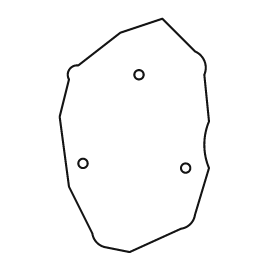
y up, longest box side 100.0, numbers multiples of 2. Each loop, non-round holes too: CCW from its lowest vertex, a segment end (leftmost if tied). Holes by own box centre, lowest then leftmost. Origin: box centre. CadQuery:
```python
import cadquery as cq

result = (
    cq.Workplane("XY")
    .moveTo(-2.0, -50.0)
    .lineTo(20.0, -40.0)
    .threePointArc((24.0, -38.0), (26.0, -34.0))
    .lineTo(32.0, -14.0)
    .threePointArc((30.0, -4.0), (32.0, 6.0))
    .lineTo(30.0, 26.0)
    .threePointArc((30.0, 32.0), (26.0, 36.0))
    .lineTo(12.0, 50.0)
    .lineTo(-6.0, 44.0)
    .lineTo(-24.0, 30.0)
    .threePointArc((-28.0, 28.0), (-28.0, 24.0))
    .lineTo(-32.0, 8.0)
    .lineTo(-28.0, -22.0)
    .lineTo(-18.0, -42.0)
    .threePointArc((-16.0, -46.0), (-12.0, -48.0))
    .close()
    .moveTo(22.0, -14.0)
    .circle(2.0)
    .moveTo(-22.0, -12.0)
    .circle(2.0)
    .moveTo(2.0, 26.0)
    .circle(2.0)
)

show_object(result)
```